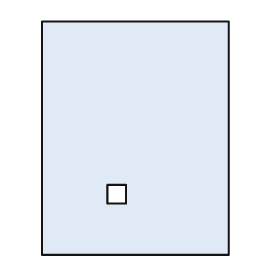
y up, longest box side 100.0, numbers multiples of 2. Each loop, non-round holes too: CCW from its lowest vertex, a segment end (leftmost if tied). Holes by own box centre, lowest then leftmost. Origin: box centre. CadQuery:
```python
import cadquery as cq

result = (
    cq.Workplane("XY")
    .moveTo(-40.0, -50.0)
    .lineTo(40.0, -50.0)
    .lineTo(40.0, 50.0)
    .lineTo(-40.0, 50.0)
    .close()
    .moveTo(-12.0, -28.0)
    .lineTo(-4.0, -28.0)
    .lineTo(-4.0, -20.0)
    .lineTo(-12.0, -20.0)
    .close()
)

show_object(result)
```